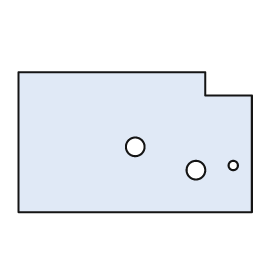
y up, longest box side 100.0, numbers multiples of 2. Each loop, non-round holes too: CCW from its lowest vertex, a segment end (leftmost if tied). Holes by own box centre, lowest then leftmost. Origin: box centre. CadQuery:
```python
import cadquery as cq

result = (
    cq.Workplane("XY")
    .moveTo(-50.0, -30.0)
    .lineTo(50.0, -30.0)
    .lineTo(50.0, 20.0)
    .lineTo(30.0, 20.0)
    .lineTo(30.0, 30.0)
    .lineTo(-50.0, 30.0)
    .close()
    .moveTo(26.0, -12.0)
    .circle(4.0)
    .moveTo(42.0, -10.0)
    .circle(2.0)
    .moveTo(0.0, -2.0)
    .circle(4.0)
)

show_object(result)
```